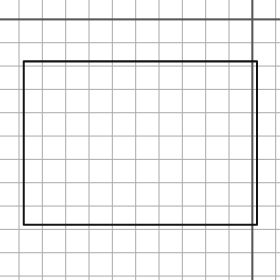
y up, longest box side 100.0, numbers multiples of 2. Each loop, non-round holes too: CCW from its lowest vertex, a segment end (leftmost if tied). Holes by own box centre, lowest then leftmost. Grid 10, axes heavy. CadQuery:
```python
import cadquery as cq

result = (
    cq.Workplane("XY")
    .moveTo(-98.0, -88.0)
    .lineTo(2.0, -88.0)
    .lineTo(2.0, -18.0)
    .lineTo(-98.0, -18.0)
    .close()
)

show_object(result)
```